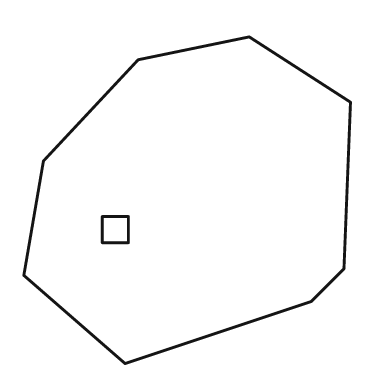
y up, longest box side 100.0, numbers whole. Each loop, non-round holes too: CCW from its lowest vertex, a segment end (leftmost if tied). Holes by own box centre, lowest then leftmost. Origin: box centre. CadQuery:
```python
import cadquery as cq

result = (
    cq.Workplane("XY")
    .moveTo(-19.0, -50.0)
    .lineTo(38.0, -31.0)
    .lineTo(48.0, -21.0)
    .lineTo(50.0, 30.0)
    .lineTo(19.0, 50.0)
    .lineTo(-15.0, 43.0)
    .lineTo(-44.0, 12.0)
    .lineTo(-50.0, -23.0)
    .close()
    .moveTo(-26.0, -13.0)
    .lineTo(-18.0, -13.0)
    .lineTo(-18.0, -5.0)
    .lineTo(-26.0, -5.0)
    .close()
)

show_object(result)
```